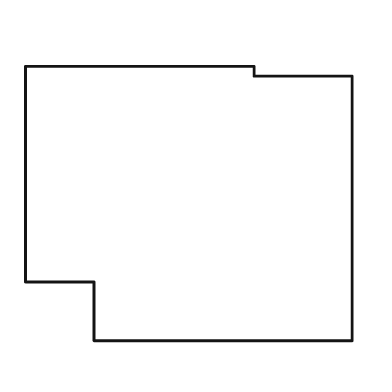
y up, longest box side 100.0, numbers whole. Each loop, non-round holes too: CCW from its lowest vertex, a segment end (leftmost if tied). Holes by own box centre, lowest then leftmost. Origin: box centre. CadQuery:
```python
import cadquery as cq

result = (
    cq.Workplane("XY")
    .moveTo(-29.0, -42.0)
    .lineTo(50.0, -42.0)
    .lineTo(50.0, 39.0)
    .lineTo(20.0, 39.0)
    .lineTo(20.0, 42.0)
    .lineTo(-50.0, 42.0)
    .lineTo(-50.0, -24.0)
    .lineTo(-29.0, -24.0)
    .close()
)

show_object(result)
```